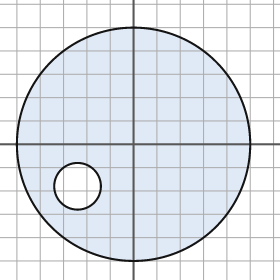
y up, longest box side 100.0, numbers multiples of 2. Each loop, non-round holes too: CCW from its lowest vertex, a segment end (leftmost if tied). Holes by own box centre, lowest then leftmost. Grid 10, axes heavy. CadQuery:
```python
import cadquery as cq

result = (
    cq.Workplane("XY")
    .moveTo(0.0, 0.0)
    .circle(50.0)
    .moveTo(-24.0, -18.0)
    .circle(10.0)
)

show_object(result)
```